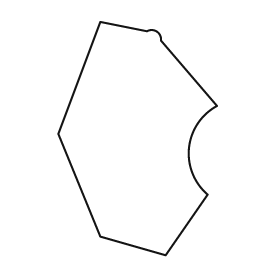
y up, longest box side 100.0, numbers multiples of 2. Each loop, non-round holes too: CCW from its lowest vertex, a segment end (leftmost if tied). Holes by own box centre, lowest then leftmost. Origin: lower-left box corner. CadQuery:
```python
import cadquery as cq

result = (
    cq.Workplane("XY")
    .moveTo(46.0, 0.0)
    .lineTo(64.0, 26.0)
    .threePointArc((56.0, 46.0), (68.0, 64.0))
    .lineTo(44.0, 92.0)
    .threePointArc((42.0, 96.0), (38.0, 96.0))
    .lineTo(18.0, 100.0)
    .lineTo(0.0, 52.0)
    .lineTo(18.0, 8.0)
    .close()
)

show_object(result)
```